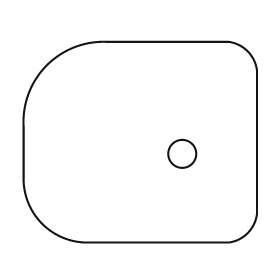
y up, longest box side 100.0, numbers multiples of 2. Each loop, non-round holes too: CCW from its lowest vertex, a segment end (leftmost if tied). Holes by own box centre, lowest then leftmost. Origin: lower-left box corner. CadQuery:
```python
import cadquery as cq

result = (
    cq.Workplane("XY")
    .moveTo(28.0, 0.0)
    .lineTo(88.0, 0.0)
    .threePointArc((96.0, 4.0), (100.0, 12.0))
    .lineTo(100.0, 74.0)
    .threePointArc((96.0, 82.0), (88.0, 86.0))
    .lineTo(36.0, 86.0)
    .threePointArc((10.0, 76.0), (0.0, 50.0))
    .lineTo(0.0, 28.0)
    .threePointArc((8.0, 8.0), (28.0, 0.0))
    .close()
    .moveTo(68.0, 38.0)
    .circle(6.0)
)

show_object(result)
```